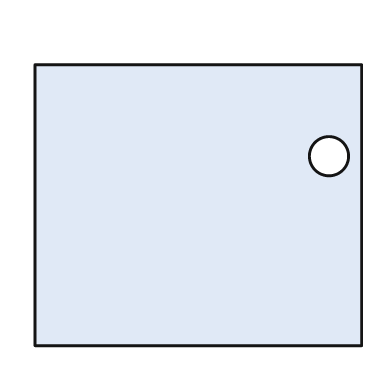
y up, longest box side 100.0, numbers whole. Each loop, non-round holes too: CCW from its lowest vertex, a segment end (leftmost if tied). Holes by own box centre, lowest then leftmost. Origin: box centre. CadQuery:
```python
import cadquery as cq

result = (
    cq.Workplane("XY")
    .moveTo(-50.0, -43.0)
    .lineTo(50.0, -43.0)
    .lineTo(50.0, 43.0)
    .lineTo(-50.0, 43.0)
    .close()
    .moveTo(40.0, 15.0)
    .circle(6.0)
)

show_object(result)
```